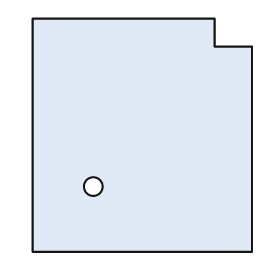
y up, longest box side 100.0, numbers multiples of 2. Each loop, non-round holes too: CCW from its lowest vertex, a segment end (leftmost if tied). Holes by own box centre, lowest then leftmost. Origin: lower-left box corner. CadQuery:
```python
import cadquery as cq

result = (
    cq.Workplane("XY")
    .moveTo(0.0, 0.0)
    .lineTo(94.0, 0.0)
    .lineTo(94.0, 88.0)
    .lineTo(78.0, 88.0)
    .lineTo(78.0, 100.0)
    .lineTo(0.0, 100.0)
    .close()
    .moveTo(26.0, 28.0)
    .circle(4.0)
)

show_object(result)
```